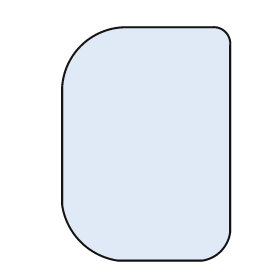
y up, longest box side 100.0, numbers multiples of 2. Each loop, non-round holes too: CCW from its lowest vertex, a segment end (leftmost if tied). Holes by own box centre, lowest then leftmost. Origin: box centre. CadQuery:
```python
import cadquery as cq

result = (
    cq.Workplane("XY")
    .moveTo(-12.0, -50.0)
    .lineTo(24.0, -50.0)
    .threePointArc((32.0, -46.0), (36.0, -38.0))
    .lineTo(36.0, 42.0)
    .threePointArc((34.0, 48.0), (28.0, 50.0))
    .lineTo(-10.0, 50.0)
    .threePointArc((-28.0, 42.0), (-36.0, 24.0))
    .lineTo(-36.0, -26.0)
    .threePointArc((-28.0, -42.0), (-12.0, -50.0))
    .close()
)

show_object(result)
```